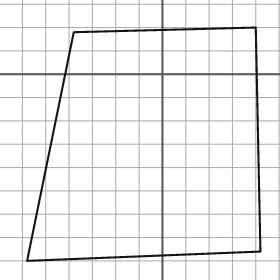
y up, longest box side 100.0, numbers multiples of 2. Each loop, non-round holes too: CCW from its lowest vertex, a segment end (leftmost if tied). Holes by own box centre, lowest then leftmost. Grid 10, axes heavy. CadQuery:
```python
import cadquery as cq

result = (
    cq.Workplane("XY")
    .moveTo(-58.0, -80.0)
    .lineTo(42.0, -76.0)
    .lineTo(40.0, 20.0)
    .lineTo(-38.0, 18.0)
    .close()
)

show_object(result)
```